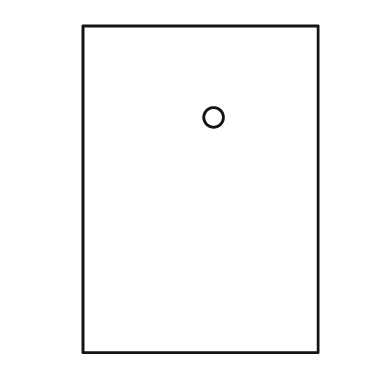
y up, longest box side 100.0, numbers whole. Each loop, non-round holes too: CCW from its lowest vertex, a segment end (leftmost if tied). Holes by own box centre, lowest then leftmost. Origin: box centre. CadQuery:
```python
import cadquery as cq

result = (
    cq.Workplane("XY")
    .moveTo(-36.0, -50.0)
    .lineTo(36.0, -50.0)
    .lineTo(36.0, 50.0)
    .lineTo(-36.0, 50.0)
    .close()
    .moveTo(4.0, 22.0)
    .circle(3.0)
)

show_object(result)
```